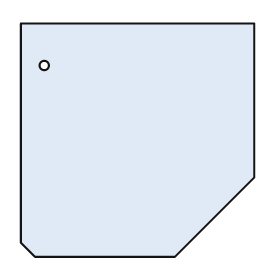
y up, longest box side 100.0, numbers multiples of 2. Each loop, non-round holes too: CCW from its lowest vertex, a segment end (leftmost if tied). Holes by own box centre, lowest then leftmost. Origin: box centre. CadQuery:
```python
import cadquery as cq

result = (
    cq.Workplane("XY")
    .moveTo(-44.0, -50.0)
    .lineTo(16.0, -50.0)
    .lineTo(50.0, -16.0)
    .lineTo(50.0, 50.0)
    .lineTo(-50.0, 50.0)
    .lineTo(-50.0, -44.0)
    .close()
    .moveTo(-40.0, 32.0)
    .circle(2.0)
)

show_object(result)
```